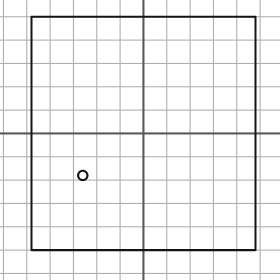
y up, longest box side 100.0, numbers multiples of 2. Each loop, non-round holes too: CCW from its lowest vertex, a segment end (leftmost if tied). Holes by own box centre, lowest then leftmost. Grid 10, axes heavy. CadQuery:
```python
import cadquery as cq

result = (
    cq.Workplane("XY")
    .moveTo(-48.0, -50.0)
    .lineTo(48.0, -50.0)
    .lineTo(48.0, 50.0)
    .lineTo(-48.0, 50.0)
    .close()
    .moveTo(-26.0, -18.0)
    .circle(2.0)
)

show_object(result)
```